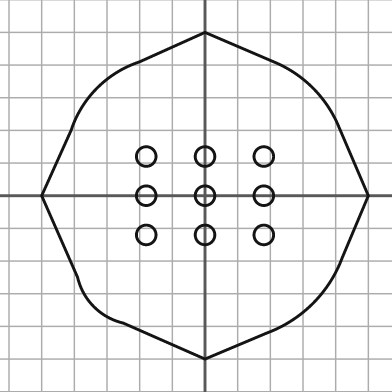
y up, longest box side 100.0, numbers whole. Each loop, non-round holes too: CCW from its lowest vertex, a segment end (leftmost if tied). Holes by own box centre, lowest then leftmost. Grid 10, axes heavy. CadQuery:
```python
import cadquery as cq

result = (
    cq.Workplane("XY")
    .moveTo(0.0, -50.0)
    .lineTo(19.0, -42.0)
    .threePointArc((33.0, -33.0), (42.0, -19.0))
    .lineTo(50.0, 0.0)
    .lineTo(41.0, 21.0)
    .threePointArc((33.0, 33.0), (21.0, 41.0))
    .lineTo(0.0, 50.0)
    .lineTo(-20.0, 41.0)
    .threePointArc((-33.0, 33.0), (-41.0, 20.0))
    .lineTo(-50.0, 0.0)
    .lineTo(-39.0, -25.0)
    .threePointArc((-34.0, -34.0), (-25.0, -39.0))
    .close()
    .moveTo(-18.0, -12.0)
    .circle(3.0)
    .moveTo(0.0, -12.0)
    .circle(3.0)
    .moveTo(18.0, -12.0)
    .circle(3.0)
    .moveTo(-18.0, 0.0)
    .circle(3.0)
    .moveTo(0.0, 0.0)
    .circle(3.0)
    .moveTo(18.0, 0.0)
    .circle(3.0)
    .moveTo(-18.0, 12.0)
    .circle(3.0)
    .moveTo(0.0, 12.0)
    .circle(3.0)
    .moveTo(18.0, 12.0)
    .circle(3.0)
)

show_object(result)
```